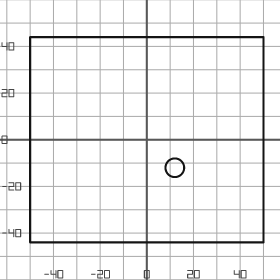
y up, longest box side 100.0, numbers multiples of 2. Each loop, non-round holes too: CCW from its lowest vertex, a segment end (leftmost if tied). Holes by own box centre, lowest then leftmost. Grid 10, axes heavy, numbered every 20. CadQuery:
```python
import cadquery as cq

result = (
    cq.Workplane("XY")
    .moveTo(-50.0, -44.0)
    .lineTo(50.0, -44.0)
    .lineTo(50.0, 44.0)
    .lineTo(-50.0, 44.0)
    .close()
    .moveTo(12.0, -12.0)
    .circle(4.0)
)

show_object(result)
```